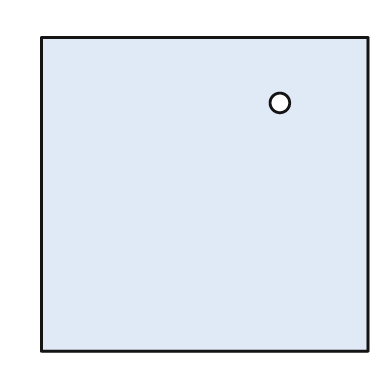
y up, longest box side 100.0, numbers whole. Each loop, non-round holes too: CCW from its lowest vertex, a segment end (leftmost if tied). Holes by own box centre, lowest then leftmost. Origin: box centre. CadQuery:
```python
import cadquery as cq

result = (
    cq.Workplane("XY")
    .moveTo(-50.0, -48.0)
    .lineTo(50.0, -48.0)
    .lineTo(50.0, 48.0)
    .lineTo(-50.0, 48.0)
    .close()
    .moveTo(23.0, 28.0)
    .circle(3.0)
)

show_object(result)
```